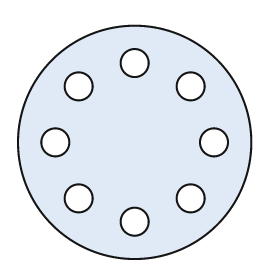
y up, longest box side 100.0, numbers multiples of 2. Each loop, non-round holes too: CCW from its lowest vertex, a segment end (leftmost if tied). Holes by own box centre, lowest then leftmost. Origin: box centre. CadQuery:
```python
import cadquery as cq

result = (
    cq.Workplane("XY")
    .moveTo(0.0, 0.0)
    .circle(50.0)
    .moveTo(0.0, -34.0)
    .circle(6.0)
    .moveTo(-24.0, -24.0)
    .circle(6.0)
    .moveTo(24.0, -24.0)
    .circle(6.0)
    .moveTo(-34.0, 0.0)
    .circle(6.0)
    .moveTo(34.0, 0.0)
    .circle(6.0)
    .moveTo(-24.0, 24.0)
    .circle(6.0)
    .moveTo(24.0, 24.0)
    .circle(6.0)
    .moveTo(0.0, 34.0)
    .circle(6.0)
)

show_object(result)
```